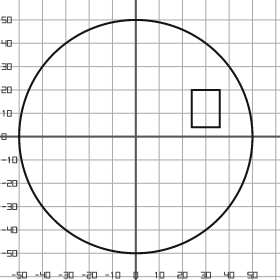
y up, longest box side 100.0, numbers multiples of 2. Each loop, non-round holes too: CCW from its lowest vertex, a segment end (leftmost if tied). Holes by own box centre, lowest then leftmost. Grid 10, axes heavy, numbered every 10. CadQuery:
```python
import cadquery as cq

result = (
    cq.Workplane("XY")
    .moveTo(0.0, 0.0)
    .circle(50.0)
    .moveTo(24.0, 4.0)
    .lineTo(36.0, 4.0)
    .lineTo(36.0, 20.0)
    .lineTo(24.0, 20.0)
    .close()
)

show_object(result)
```